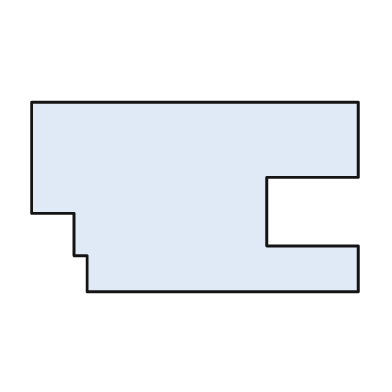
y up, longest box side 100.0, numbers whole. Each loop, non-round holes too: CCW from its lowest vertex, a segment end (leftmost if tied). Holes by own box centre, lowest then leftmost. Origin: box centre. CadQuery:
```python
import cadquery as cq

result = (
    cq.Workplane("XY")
    .moveTo(-33.0, -29.0)
    .lineTo(50.0, -29.0)
    .lineTo(50.0, -15.0)
    .lineTo(22.0, -15.0)
    .lineTo(22.0, 6.0)
    .lineTo(50.0, 6.0)
    .lineTo(50.0, 29.0)
    .lineTo(-50.0, 29.0)
    .lineTo(-50.0, -5.0)
    .lineTo(-37.0, -5.0)
    .lineTo(-37.0, -18.0)
    .lineTo(-33.0, -18.0)
    .close()
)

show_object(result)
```